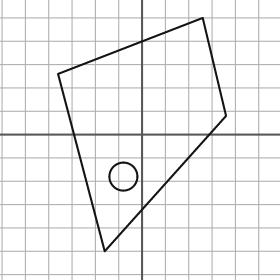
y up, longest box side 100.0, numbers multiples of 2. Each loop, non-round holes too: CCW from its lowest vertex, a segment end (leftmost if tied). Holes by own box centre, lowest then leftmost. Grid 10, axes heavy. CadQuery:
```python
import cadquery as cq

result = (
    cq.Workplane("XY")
    .moveTo(-16.0, -50.0)
    .lineTo(36.0, 8.0)
    .lineTo(26.0, 50.0)
    .lineTo(-36.0, 26.0)
    .close()
    .moveTo(-8.0, -18.0)
    .circle(6.0)
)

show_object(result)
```